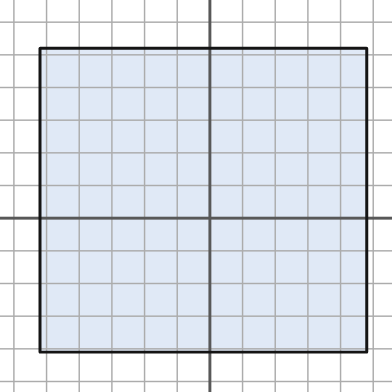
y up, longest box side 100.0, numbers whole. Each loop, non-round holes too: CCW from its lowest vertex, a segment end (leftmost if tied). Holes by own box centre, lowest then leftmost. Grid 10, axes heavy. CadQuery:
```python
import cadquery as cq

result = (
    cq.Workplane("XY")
    .moveTo(-52.0, -41.0)
    .lineTo(48.0, -41.0)
    .lineTo(48.0, 52.0)
    .lineTo(-52.0, 52.0)
    .close()
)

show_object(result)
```